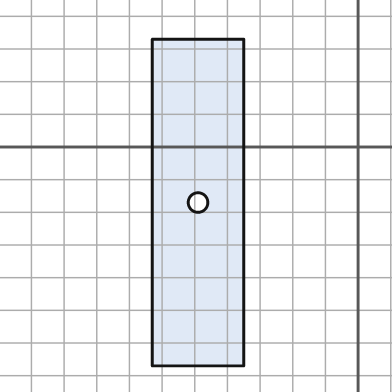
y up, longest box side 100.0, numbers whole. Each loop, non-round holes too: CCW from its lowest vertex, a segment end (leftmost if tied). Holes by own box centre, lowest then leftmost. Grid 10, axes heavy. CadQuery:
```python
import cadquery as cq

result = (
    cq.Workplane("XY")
    .moveTo(-63.0, -67.0)
    .lineTo(-35.0, -67.0)
    .lineTo(-35.0, 33.0)
    .lineTo(-63.0, 33.0)
    .close()
    .moveTo(-49.0, -17.0)
    .circle(3.0)
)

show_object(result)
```